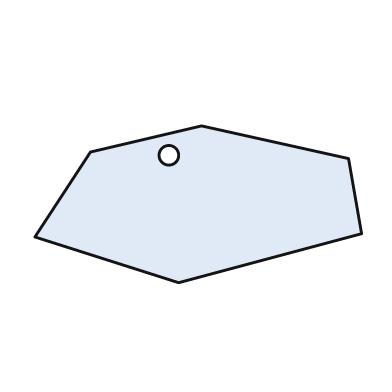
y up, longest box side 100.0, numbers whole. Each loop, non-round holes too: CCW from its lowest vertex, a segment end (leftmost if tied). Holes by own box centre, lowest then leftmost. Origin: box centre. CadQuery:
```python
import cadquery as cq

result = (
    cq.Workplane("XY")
    .moveTo(-6.0, -24.0)
    .lineTo(50.0, -9.0)
    .lineTo(46.0, 14.0)
    .lineTo(1.0, 24.0)
    .lineTo(-33.0, 16.0)
    .lineTo(-50.0, -10.0)
    .close()
    .moveTo(-9.0, 15.0)
    .circle(3.0)
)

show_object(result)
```